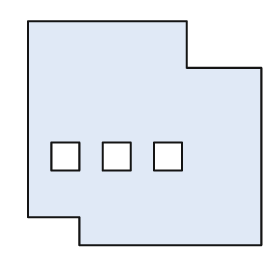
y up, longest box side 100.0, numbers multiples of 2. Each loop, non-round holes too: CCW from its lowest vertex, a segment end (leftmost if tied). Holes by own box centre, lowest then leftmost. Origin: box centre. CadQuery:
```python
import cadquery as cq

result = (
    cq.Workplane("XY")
    .moveTo(-28.0, -48.0)
    .lineTo(50.0, -48.0)
    .lineTo(50.0, 28.0)
    .lineTo(18.0, 28.0)
    .lineTo(18.0, 48.0)
    .lineTo(-50.0, 48.0)
    .lineTo(-50.0, -36.0)
    .lineTo(-28.0, -36.0)
    .close()
    .moveTo(-40.0, -16.0)
    .lineTo(-28.0, -16.0)
    .lineTo(-28.0, -4.0)
    .lineTo(-40.0, -4.0)
    .close()
    .moveTo(-18.0, -16.0)
    .lineTo(-6.0, -16.0)
    .lineTo(-6.0, -4.0)
    .lineTo(-18.0, -4.0)
    .close()
    .moveTo(4.0, -16.0)
    .lineTo(16.0, -16.0)
    .lineTo(16.0, -4.0)
    .lineTo(4.0, -4.0)
    .close()
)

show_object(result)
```